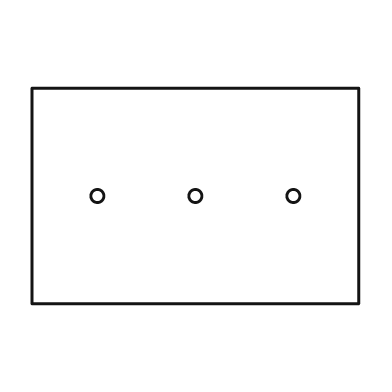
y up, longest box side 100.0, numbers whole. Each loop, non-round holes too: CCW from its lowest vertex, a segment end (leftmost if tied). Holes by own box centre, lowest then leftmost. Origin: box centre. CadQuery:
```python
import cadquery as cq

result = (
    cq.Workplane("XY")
    .moveTo(-50.0, -33.0)
    .lineTo(50.0, -33.0)
    .lineTo(50.0, 33.0)
    .lineTo(-50.0, 33.0)
    .close()
    .moveTo(-30.0, 0.0)
    .circle(2.0)
    .moveTo(0.0, 0.0)
    .circle(2.0)
    .moveTo(30.0, 0.0)
    .circle(2.0)
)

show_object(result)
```